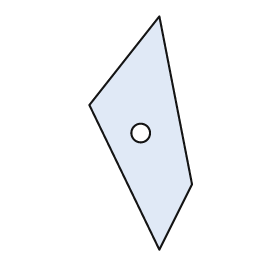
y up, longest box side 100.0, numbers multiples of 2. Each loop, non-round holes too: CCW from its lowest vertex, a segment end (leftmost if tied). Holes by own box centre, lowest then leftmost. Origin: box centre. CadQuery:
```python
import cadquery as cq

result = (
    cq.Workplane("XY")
    .moveTo(8.0, -50.0)
    .lineTo(22.0, -22.0)
    .lineTo(8.0, 50.0)
    .lineTo(-22.0, 12.0)
    .close()
    .moveTo(0.0, 0.0)
    .circle(4.0)
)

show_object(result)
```